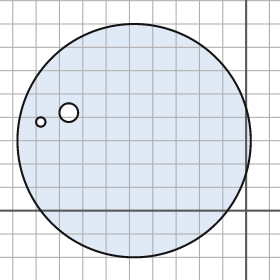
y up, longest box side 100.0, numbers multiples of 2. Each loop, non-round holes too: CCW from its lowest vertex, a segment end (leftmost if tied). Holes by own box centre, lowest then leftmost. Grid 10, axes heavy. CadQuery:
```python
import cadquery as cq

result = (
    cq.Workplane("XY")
    .moveTo(-48.0, 30.0)
    .circle(50.0)
    .moveTo(-88.0, 38.0)
    .circle(2.0)
    .moveTo(-76.0, 42.0)
    .circle(4.0)
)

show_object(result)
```